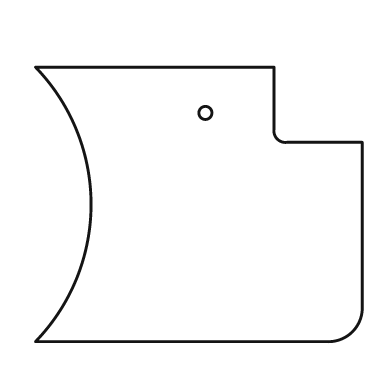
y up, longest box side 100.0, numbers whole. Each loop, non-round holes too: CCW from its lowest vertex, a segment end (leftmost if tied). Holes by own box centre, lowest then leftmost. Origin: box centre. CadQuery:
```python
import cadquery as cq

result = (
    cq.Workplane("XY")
    .moveTo(-50.0, -42.0)
    .lineTo(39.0, -42.0)
    .threePointArc((47.0, -39.0), (50.0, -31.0))
    .lineTo(50.0, 19.0)
    .lineTo(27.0, 19.0)
    .threePointArc((24.0, 20.0), (23.0, 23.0))
    .lineTo(23.0, 42.0)
    .lineTo(-50.0, 42.0)
    .threePointArc((-33.0, 0.0), (-50.0, -42.0))
    .close()
    .moveTo(2.0, 28.0)
    .circle(2.0)
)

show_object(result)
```